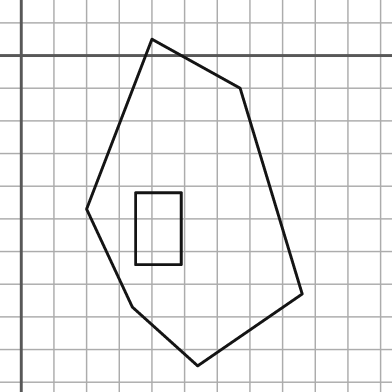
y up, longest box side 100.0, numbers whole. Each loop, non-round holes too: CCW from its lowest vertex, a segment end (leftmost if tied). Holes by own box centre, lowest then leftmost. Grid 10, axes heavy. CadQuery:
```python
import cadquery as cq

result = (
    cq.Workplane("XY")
    .moveTo(54.0, -95.0)
    .lineTo(86.0, -73.0)
    .lineTo(67.0, -10.0)
    .lineTo(40.0, 5.0)
    .lineTo(20.0, -47.0)
    .lineTo(34.0, -77.0)
    .close()
    .moveTo(35.0, -64.0)
    .lineTo(49.0, -64.0)
    .lineTo(49.0, -42.0)
    .lineTo(35.0, -42.0)
    .close()
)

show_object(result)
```